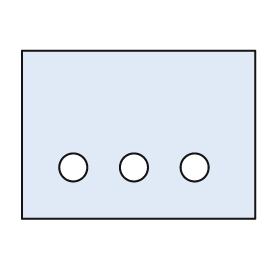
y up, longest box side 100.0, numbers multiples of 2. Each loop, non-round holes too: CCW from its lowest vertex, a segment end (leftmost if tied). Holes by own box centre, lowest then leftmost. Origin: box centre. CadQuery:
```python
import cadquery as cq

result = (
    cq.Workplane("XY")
    .moveTo(-50.0, -36.0)
    .lineTo(50.0, -36.0)
    .lineTo(50.0, 36.0)
    .lineTo(-50.0, 36.0)
    .close()
    .moveTo(-28.0, -14.0)
    .circle(6.0)
    .moveTo(-2.0, -14.0)
    .circle(6.0)
    .moveTo(24.0, -14.0)
    .circle(6.0)
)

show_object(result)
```